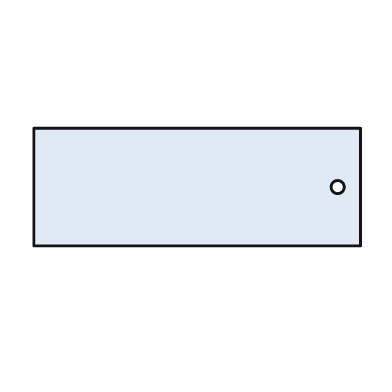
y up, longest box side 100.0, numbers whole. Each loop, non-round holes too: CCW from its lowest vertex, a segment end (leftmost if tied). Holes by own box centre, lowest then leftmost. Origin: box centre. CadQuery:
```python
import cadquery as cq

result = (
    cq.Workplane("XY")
    .moveTo(-50.0, -18.0)
    .lineTo(50.0, -18.0)
    .lineTo(50.0, 18.0)
    .lineTo(-50.0, 18.0)
    .close()
    .moveTo(43.0, 0.0)
    .circle(2.0)
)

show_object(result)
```